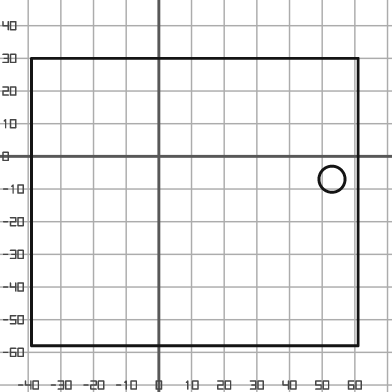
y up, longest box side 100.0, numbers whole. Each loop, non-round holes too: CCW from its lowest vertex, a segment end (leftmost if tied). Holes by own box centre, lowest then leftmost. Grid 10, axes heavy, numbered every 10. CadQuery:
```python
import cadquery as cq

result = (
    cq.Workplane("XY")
    .moveTo(-39.0, -58.0)
    .lineTo(61.0, -58.0)
    .lineTo(61.0, 30.0)
    .lineTo(-39.0, 30.0)
    .close()
    .moveTo(53.0, -7.0)
    .circle(4.0)
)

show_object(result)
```